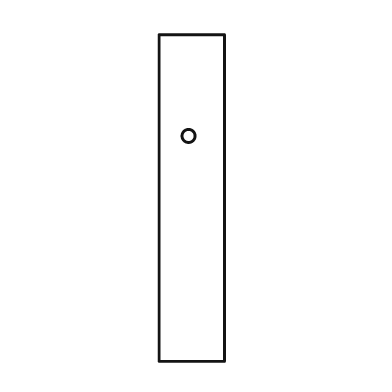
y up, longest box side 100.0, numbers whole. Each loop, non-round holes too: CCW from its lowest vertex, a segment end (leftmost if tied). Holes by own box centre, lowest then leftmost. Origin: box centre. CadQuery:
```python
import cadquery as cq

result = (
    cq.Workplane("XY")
    .moveTo(-10.0, -50.0)
    .lineTo(10.0, -50.0)
    .lineTo(10.0, 50.0)
    .lineTo(-10.0, 50.0)
    .close()
    .moveTo(-1.0, 19.0)
    .circle(2.0)
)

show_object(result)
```